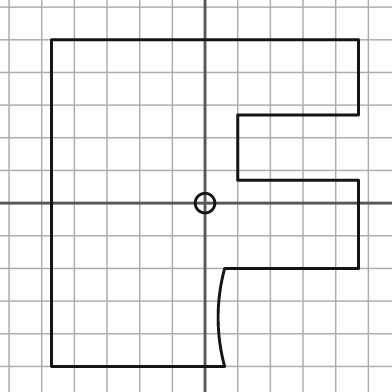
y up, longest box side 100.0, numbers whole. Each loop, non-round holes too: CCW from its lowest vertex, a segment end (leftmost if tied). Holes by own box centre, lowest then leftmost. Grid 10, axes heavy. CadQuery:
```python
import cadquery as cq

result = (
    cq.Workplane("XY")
    .moveTo(-47.0, -50.0)
    .lineTo(6.0, -50.0)
    .threePointArc((4.0, -35.0), (6.0, -20.0))
    .lineTo(47.0, -20.0)
    .lineTo(47.0, 7.0)
    .lineTo(10.0, 7.0)
    .lineTo(10.0, 27.0)
    .lineTo(47.0, 27.0)
    .lineTo(47.0, 50.0)
    .lineTo(-47.0, 50.0)
    .close()
    .moveTo(0.0, 0.0)
    .circle(3.0)
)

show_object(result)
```